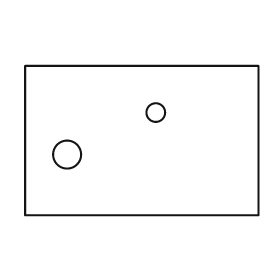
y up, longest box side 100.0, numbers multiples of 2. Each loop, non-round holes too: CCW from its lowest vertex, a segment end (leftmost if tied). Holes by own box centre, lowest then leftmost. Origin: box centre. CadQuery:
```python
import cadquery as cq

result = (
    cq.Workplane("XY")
    .moveTo(-50.0, -32.0)
    .lineTo(50.0, -32.0)
    .lineTo(50.0, 32.0)
    .lineTo(-50.0, 32.0)
    .close()
    .moveTo(-32.0, -6.0)
    .circle(6.0)
    .moveTo(6.0, 12.0)
    .circle(4.0)
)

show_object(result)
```